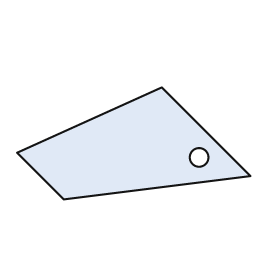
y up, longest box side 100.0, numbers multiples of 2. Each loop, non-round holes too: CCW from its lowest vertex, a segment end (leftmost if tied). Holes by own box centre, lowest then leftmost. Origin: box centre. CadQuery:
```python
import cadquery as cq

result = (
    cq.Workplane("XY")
    .moveTo(-30.0, -24.0)
    .lineTo(50.0, -14.0)
    .lineTo(12.0, 24.0)
    .lineTo(-50.0, -4.0)
    .close()
    .moveTo(28.0, -6.0)
    .circle(4.0)
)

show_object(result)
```